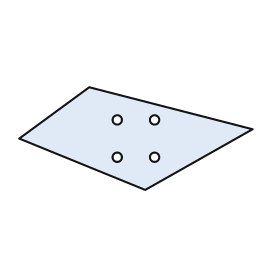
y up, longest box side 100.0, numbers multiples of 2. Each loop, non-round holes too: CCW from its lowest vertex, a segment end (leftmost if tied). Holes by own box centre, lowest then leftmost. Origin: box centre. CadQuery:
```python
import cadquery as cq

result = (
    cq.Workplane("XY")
    .moveTo(4.0, -22.0)
    .lineTo(50.0, 4.0)
    .lineTo(-20.0, 22.0)
    .lineTo(-50.0, 0.0)
    .close()
    .moveTo(-8.0, -8.0)
    .circle(2.0)
    .moveTo(8.0, -8.0)
    .circle(2.0)
    .moveTo(-8.0, 8.0)
    .circle(2.0)
    .moveTo(8.0, 8.0)
    .circle(2.0)
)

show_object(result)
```